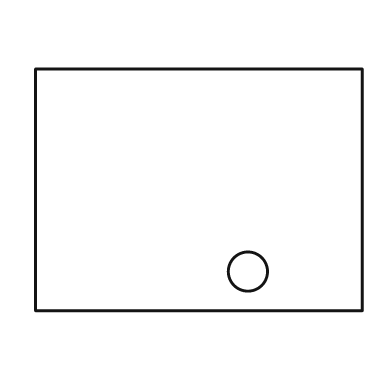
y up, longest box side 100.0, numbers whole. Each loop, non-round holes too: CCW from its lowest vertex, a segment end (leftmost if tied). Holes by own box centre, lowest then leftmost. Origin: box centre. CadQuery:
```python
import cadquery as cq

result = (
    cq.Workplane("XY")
    .moveTo(-50.0, -37.0)
    .lineTo(50.0, -37.0)
    .lineTo(50.0, 37.0)
    .lineTo(-50.0, 37.0)
    .close()
    .moveTo(15.0, -25.0)
    .circle(6.0)
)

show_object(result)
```